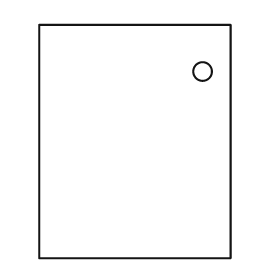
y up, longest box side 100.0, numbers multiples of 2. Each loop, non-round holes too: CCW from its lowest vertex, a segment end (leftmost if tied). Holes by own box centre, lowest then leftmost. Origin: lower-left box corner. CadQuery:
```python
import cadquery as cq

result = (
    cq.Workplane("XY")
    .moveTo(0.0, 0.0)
    .lineTo(82.0, 0.0)
    .lineTo(82.0, 100.0)
    .lineTo(0.0, 100.0)
    .close()
    .moveTo(70.0, 80.0)
    .circle(4.0)
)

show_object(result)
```